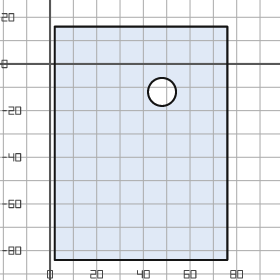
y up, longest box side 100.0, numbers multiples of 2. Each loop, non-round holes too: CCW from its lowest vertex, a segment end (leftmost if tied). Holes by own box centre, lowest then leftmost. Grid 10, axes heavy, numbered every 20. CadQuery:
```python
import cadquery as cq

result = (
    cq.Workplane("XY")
    .moveTo(2.0, -84.0)
    .lineTo(76.0, -84.0)
    .lineTo(76.0, 16.0)
    .lineTo(2.0, 16.0)
    .close()
    .moveTo(48.0, -12.0)
    .circle(6.0)
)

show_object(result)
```